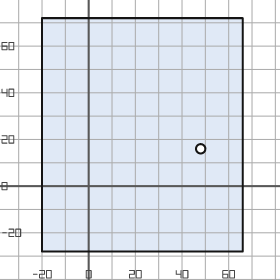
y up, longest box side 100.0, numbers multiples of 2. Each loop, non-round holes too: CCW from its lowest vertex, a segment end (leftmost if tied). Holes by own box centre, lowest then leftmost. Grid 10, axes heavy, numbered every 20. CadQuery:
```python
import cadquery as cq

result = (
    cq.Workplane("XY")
    .moveTo(-20.0, -28.0)
    .lineTo(66.0, -28.0)
    .lineTo(66.0, 72.0)
    .lineTo(-20.0, 72.0)
    .close()
    .moveTo(48.0, 16.0)
    .circle(2.0)
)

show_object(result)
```